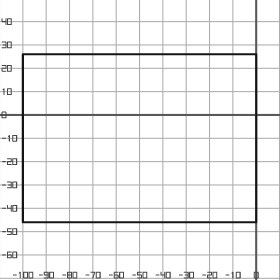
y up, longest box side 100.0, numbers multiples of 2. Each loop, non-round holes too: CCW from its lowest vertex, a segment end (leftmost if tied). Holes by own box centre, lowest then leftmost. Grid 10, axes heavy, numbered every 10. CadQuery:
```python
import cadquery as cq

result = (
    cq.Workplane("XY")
    .moveTo(-100.0, -46.0)
    .lineTo(0.0, -46.0)
    .lineTo(0.0, 26.0)
    .lineTo(-100.0, 26.0)
    .close()
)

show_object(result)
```